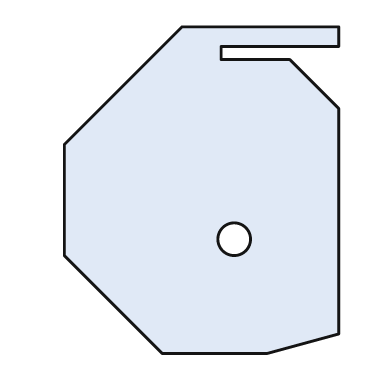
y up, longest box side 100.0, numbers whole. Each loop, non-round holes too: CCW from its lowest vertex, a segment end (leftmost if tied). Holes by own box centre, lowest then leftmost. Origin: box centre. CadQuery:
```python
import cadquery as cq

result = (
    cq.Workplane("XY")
    .moveTo(-12.0, -50.0)
    .lineTo(20.0, -50.0)
    .lineTo(42.0, -44.0)
    .lineTo(42.0, 25.0)
    .lineTo(27.0, 40.0)
    .lineTo(6.0, 40.0)
    .lineTo(6.0, 44.0)
    .lineTo(42.0, 44.0)
    .lineTo(42.0, 50.0)
    .lineTo(-6.0, 50.0)
    .lineTo(-42.0, 14.0)
    .lineTo(-42.0, -20.0)
    .close()
    .moveTo(10.0, -15.0)
    .circle(5.0)
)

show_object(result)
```